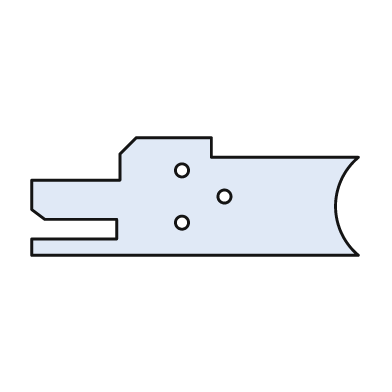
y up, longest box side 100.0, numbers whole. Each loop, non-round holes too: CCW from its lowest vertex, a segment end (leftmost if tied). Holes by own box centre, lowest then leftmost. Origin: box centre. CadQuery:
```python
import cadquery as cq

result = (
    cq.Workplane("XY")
    .moveTo(-50.0, -18.0)
    .lineTo(50.0, -18.0)
    .threePointArc((43.0, -3.0), (50.0, 12.0))
    .lineTo(5.0, 12.0)
    .lineTo(5.0, 18.0)
    .lineTo(-18.0, 18.0)
    .lineTo(-23.0, 13.0)
    .lineTo(-23.0, 5.0)
    .lineTo(-50.0, 5.0)
    .lineTo(-50.0, -4.0)
    .lineTo(-46.0, -7.0)
    .lineTo(-24.0, -7.0)
    .lineTo(-24.0, -13.0)
    .lineTo(-50.0, -13.0)
    .close()
    .moveTo(-4.0, -8.0)
    .circle(2.0)
    .moveTo(9.0, 0.0)
    .circle(2.0)
    .moveTo(-4.0, 8.0)
    .circle(2.0)
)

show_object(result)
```